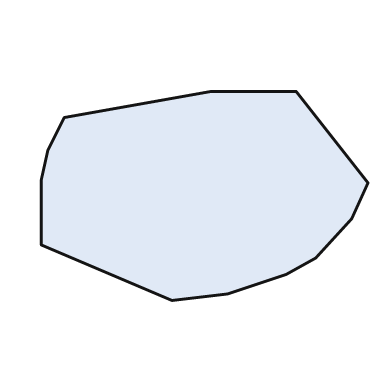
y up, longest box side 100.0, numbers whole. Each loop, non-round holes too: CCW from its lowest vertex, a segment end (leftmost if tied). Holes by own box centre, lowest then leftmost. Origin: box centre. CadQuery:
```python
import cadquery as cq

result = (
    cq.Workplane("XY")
    .moveTo(-10.0, -32.0)
    .lineTo(7.0, -30.0)
    .lineTo(25.0, -24.0)
    .lineTo(34.0, -19.0)
    .lineTo(45.0, -7.0)
    .lineTo(50.0, 4.0)
    .lineTo(28.0, 32.0)
    .lineTo(2.0, 32.0)
    .lineTo(-43.0, 24.0)
    .lineTo(-48.0, 14.0)
    .lineTo(-50.0, 5.0)
    .lineTo(-50.0, -15.0)
    .close()
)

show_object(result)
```